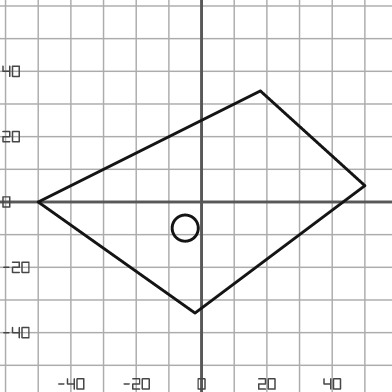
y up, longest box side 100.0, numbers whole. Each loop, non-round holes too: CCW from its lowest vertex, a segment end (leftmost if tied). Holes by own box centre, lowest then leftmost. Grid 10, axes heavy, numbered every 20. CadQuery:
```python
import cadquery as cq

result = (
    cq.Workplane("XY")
    .moveTo(-2.0, -34.0)
    .lineTo(50.0, 5.0)
    .lineTo(18.0, 34.0)
    .lineTo(-50.0, 0.0)
    .close()
    .moveTo(-5.0, -8.0)
    .circle(4.0)
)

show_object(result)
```